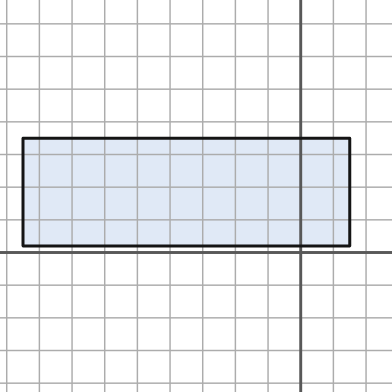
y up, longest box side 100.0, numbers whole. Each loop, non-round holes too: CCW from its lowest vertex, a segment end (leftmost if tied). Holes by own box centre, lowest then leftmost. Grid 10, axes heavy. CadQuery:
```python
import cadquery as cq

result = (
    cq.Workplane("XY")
    .moveTo(-85.0, 2.0)
    .lineTo(15.0, 2.0)
    .lineTo(15.0, 35.0)
    .lineTo(-85.0, 35.0)
    .close()
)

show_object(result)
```